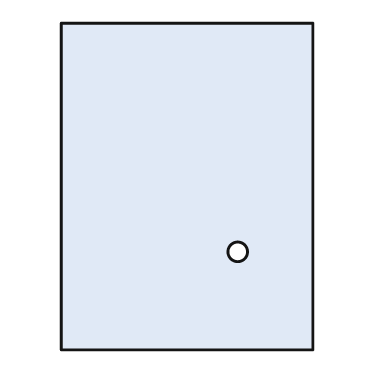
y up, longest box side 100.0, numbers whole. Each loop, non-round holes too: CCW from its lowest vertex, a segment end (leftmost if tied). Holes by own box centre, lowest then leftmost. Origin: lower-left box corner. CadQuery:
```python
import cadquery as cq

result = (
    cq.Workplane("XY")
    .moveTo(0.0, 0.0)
    .lineTo(77.0, 0.0)
    .lineTo(77.0, 100.0)
    .lineTo(0.0, 100.0)
    .close()
    .moveTo(54.0, 30.0)
    .circle(3.0)
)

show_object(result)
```